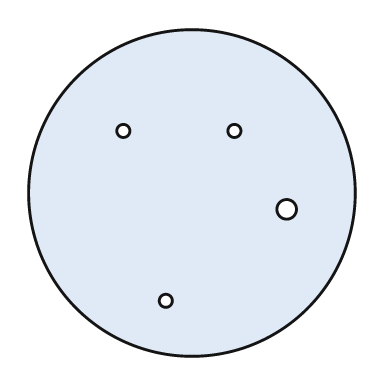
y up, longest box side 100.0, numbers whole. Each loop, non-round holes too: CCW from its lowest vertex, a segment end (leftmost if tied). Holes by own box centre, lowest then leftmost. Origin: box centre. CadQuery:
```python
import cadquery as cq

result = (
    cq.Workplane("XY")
    .moveTo(0.0, 0.0)
    .circle(50.0)
    .moveTo(-8.0, -33.0)
    .circle(2.0)
    .moveTo(29.0, -5.0)
    .circle(3.0)
    .moveTo(-21.0, 19.0)
    .circle(2.0)
    .moveTo(13.0, 19.0)
    .circle(2.0)
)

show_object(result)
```